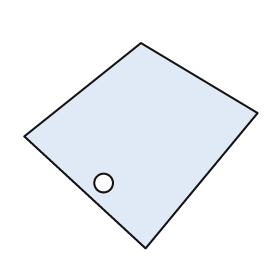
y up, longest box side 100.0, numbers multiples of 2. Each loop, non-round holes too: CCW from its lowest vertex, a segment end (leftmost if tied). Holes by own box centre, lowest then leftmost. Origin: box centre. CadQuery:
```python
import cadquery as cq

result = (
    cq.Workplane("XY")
    .moveTo(2.0, -44.0)
    .lineTo(50.0, 14.0)
    .lineTo(0.0, 44.0)
    .lineTo(-50.0, 4.0)
    .close()
    .moveTo(-16.0, -16.0)
    .circle(4.0)
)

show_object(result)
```